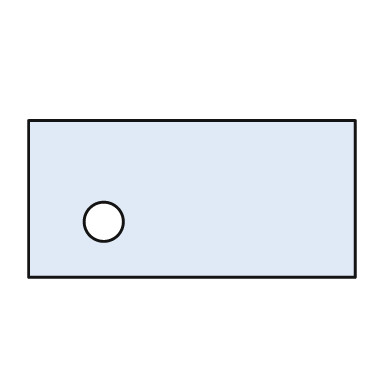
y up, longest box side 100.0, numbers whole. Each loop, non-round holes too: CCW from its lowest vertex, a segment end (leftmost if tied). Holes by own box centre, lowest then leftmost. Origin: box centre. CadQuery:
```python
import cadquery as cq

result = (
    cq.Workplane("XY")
    .moveTo(-50.0, -24.0)
    .lineTo(50.0, -24.0)
    .lineTo(50.0, 24.0)
    .lineTo(-50.0, 24.0)
    .close()
    .moveTo(-27.0, -7.0)
    .circle(6.0)
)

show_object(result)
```